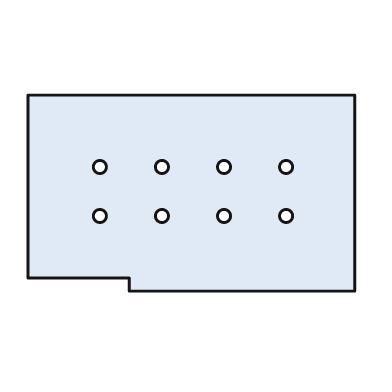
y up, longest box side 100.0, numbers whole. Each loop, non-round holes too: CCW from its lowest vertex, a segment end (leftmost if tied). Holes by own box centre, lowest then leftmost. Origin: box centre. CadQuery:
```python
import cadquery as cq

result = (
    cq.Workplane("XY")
    .moveTo(-19.0, -30.0)
    .lineTo(50.0, -30.0)
    .lineTo(50.0, 30.0)
    .lineTo(-50.0, 30.0)
    .lineTo(-50.0, -26.0)
    .lineTo(-19.0, -26.0)
    .close()
    .moveTo(-28.0, -7.0)
    .circle(2.0)
    .moveTo(-9.0, -7.0)
    .circle(2.0)
    .moveTo(10.0, -7.0)
    .circle(2.0)
    .moveTo(29.0, -7.0)
    .circle(2.0)
    .moveTo(-28.0, 8.0)
    .circle(2.0)
    .moveTo(-9.0, 8.0)
    .circle(2.0)
    .moveTo(10.0, 8.0)
    .circle(2.0)
    .moveTo(29.0, 8.0)
    .circle(2.0)
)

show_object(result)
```